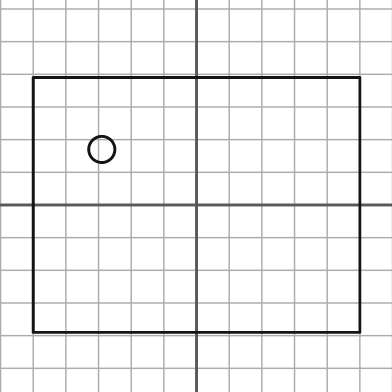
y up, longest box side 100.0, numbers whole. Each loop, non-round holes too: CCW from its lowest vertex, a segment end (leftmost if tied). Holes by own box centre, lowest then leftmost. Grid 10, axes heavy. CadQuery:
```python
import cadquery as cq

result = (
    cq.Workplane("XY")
    .moveTo(-50.0, -39.0)
    .lineTo(50.0, -39.0)
    .lineTo(50.0, 39.0)
    .lineTo(-50.0, 39.0)
    .close()
    .moveTo(-29.0, 17.0)
    .circle(4.0)
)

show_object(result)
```